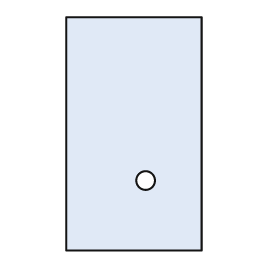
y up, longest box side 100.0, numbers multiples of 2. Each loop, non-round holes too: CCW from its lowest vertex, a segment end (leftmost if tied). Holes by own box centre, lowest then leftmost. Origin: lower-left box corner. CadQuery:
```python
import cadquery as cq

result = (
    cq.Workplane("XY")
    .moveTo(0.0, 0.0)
    .lineTo(58.0, 0.0)
    .lineTo(58.0, 100.0)
    .lineTo(0.0, 100.0)
    .close()
    .moveTo(34.0, 30.0)
    .circle(4.0)
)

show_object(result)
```